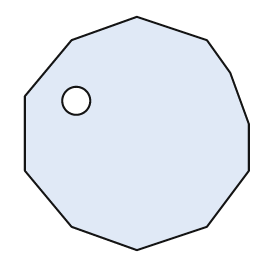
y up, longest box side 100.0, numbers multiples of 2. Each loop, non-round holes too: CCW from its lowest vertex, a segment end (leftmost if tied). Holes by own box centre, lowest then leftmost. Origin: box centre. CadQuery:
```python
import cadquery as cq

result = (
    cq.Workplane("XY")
    .moveTo(0.0, -50.0)
    .lineTo(30.0, -40.0)
    .lineTo(48.0, -16.0)
    .lineTo(48.0, 4.0)
    .lineTo(40.0, 26.0)
    .lineTo(30.0, 40.0)
    .lineTo(0.0, 50.0)
    .lineTo(-28.0, 40.0)
    .lineTo(-48.0, 16.0)
    .lineTo(-48.0, -16.0)
    .lineTo(-28.0, -40.0)
    .close()
    .moveTo(-26.0, 14.0)
    .circle(6.0)
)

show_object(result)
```